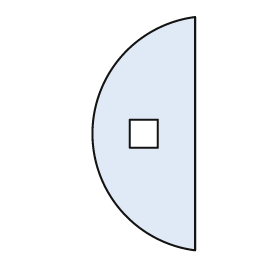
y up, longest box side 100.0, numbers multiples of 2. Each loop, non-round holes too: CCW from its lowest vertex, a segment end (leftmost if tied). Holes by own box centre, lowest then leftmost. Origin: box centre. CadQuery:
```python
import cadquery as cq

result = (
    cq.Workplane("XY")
    .moveTo(22.0, -50.0)
    .lineTo(22.0, 50.0)
    .threePointArc((-22.0, 0.0), (22.0, -50.0))
    .close()
    .moveTo(-6.0, -6.0)
    .lineTo(6.0, -6.0)
    .lineTo(6.0, 6.0)
    .lineTo(-6.0, 6.0)
    .close()
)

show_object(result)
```